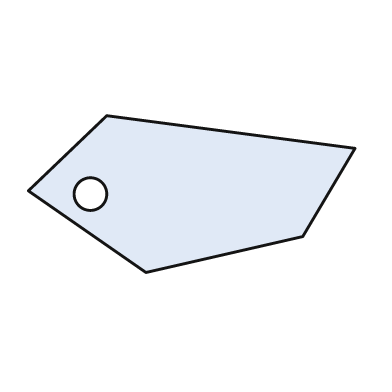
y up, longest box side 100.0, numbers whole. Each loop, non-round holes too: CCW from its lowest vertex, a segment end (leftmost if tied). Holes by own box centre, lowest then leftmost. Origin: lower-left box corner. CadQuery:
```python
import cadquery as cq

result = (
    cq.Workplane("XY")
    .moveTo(36.0, 0.0)
    .lineTo(84.0, 11.0)
    .lineTo(100.0, 38.0)
    .lineTo(24.0, 48.0)
    .lineTo(0.0, 25.0)
    .close()
    .moveTo(19.0, 24.0)
    .circle(5.0)
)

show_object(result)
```